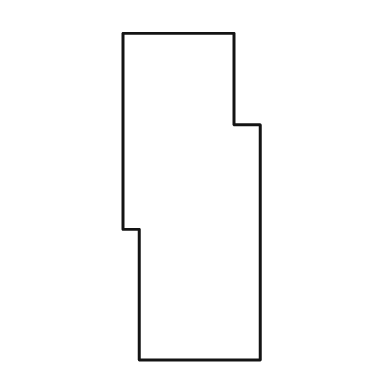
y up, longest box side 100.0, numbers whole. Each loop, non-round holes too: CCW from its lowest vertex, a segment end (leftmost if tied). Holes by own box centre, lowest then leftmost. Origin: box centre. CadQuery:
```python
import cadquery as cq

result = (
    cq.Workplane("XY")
    .moveTo(-16.0, -50.0)
    .lineTo(21.0, -50.0)
    .lineTo(21.0, 22.0)
    .lineTo(13.0, 22.0)
    .lineTo(13.0, 50.0)
    .lineTo(-21.0, 50.0)
    .lineTo(-21.0, -10.0)
    .lineTo(-16.0, -10.0)
    .close()
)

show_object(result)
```